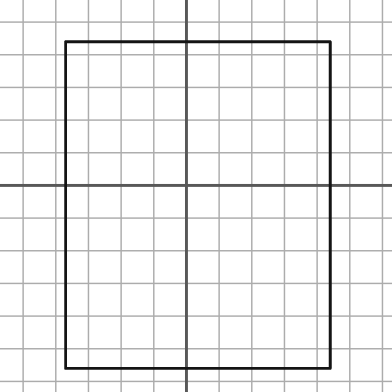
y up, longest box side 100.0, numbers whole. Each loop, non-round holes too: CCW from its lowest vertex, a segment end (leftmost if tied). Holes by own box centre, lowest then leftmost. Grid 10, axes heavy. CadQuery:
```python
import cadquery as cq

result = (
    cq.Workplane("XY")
    .moveTo(-37.0, -56.0)
    .lineTo(44.0, -56.0)
    .lineTo(44.0, 44.0)
    .lineTo(-37.0, 44.0)
    .close()
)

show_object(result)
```